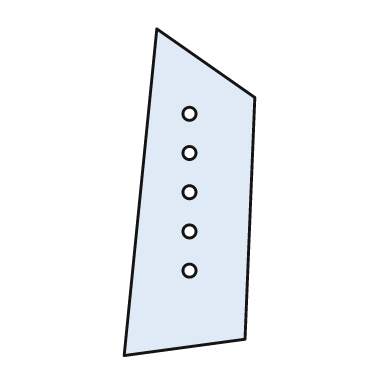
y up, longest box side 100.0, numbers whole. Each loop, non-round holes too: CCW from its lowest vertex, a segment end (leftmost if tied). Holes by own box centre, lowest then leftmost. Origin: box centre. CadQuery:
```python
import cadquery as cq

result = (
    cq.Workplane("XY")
    .moveTo(-20.0, -50.0)
    .lineTo(17.0, -45.0)
    .lineTo(20.0, 29.0)
    .lineTo(-10.0, 50.0)
    .close()
    .moveTo(0.0, -24.0)
    .circle(2.0)
    .moveTo(0.0, -12.0)
    .circle(2.0)
    .moveTo(0.0, 0.0)
    .circle(2.0)
    .moveTo(0.0, 12.0)
    .circle(2.0)
    .moveTo(0.0, 24.0)
    .circle(2.0)
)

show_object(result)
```